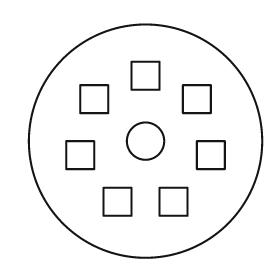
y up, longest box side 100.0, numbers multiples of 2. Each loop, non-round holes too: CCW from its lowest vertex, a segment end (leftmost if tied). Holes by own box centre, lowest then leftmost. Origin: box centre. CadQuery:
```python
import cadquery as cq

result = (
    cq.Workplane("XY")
    .moveTo(0.0, 0.0)
    .circle(50.0)
    .moveTo(-18.0, -32.0)
    .lineTo(-6.0, -32.0)
    .lineTo(-6.0, -20.0)
    .lineTo(-18.0, -20.0)
    .close()
    .moveTo(6.0, -32.0)
    .lineTo(18.0, -32.0)
    .lineTo(18.0, -20.0)
    .lineTo(6.0, -20.0)
    .close()
    .moveTo(-34.0, -12.0)
    .lineTo(-22.0, -12.0)
    .lineTo(-22.0, 0.0)
    .lineTo(-34.0, 0.0)
    .close()
    .moveTo(22.0, -12.0)
    .lineTo(34.0, -12.0)
    .lineTo(34.0, 0.0)
    .lineTo(22.0, 0.0)
    .close()
    .moveTo(0.0, 0.0)
    .circle(8.0)
    .moveTo(-28.0, 12.0)
    .lineTo(-16.0, 12.0)
    .lineTo(-16.0, 24.0)
    .lineTo(-28.0, 24.0)
    .close()
    .moveTo(16.0, 12.0)
    .lineTo(28.0, 12.0)
    .lineTo(28.0, 24.0)
    .lineTo(16.0, 24.0)
    .close()
    .moveTo(-6.0, 22.0)
    .lineTo(6.0, 22.0)
    .lineTo(6.0, 34.0)
    .lineTo(-6.0, 34.0)
    .close()
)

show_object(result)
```